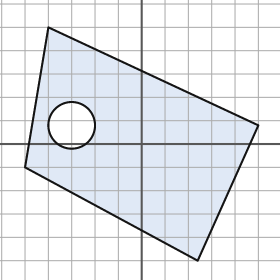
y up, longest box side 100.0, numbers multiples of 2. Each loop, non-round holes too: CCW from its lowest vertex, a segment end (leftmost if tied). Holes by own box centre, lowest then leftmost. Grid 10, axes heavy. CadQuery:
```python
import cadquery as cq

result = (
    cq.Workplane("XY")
    .moveTo(24.0, -50.0)
    .lineTo(50.0, 8.0)
    .lineTo(-40.0, 50.0)
    .lineTo(-50.0, -10.0)
    .close()
    .moveTo(-30.0, 8.0)
    .circle(10.0)
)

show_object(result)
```